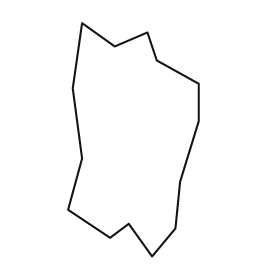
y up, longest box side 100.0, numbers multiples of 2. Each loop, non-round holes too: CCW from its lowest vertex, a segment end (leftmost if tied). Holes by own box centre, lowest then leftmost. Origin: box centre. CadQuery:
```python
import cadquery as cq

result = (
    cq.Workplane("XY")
    .moveTo(8.0, -50.0)
    .lineTo(18.0, -38.0)
    .lineTo(20.0, -18.0)
    .lineTo(28.0, 8.0)
    .lineTo(28.0, 24.0)
    .lineTo(10.0, 34.0)
    .lineTo(6.0, 46.0)
    .lineTo(-8.0, 40.0)
    .lineTo(-22.0, 50.0)
    .lineTo(-26.0, 22.0)
    .lineTo(-22.0, -8.0)
    .lineTo(-28.0, -30.0)
    .lineTo(-10.0, -42.0)
    .lineTo(-2.0, -36.0)
    .close()
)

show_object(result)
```